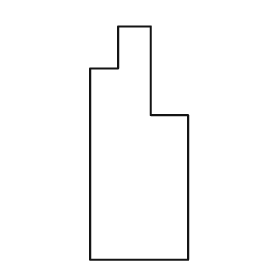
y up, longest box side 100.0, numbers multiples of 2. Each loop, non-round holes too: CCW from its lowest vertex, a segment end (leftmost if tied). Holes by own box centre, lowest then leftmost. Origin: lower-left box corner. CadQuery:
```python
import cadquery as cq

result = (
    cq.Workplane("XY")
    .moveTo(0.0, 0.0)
    .lineTo(42.0, 0.0)
    .lineTo(42.0, 62.0)
    .lineTo(26.0, 62.0)
    .lineTo(26.0, 100.0)
    .lineTo(12.0, 100.0)
    .lineTo(12.0, 82.0)
    .lineTo(0.0, 82.0)
    .close()
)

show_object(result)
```